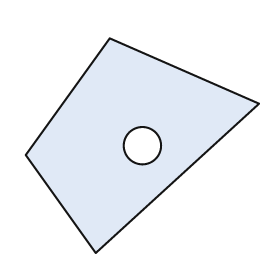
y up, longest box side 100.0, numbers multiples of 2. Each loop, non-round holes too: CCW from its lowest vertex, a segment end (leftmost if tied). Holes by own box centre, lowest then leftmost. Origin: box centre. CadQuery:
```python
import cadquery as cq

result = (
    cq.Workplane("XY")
    .moveTo(-20.0, -46.0)
    .lineTo(50.0, 18.0)
    .lineTo(-14.0, 46.0)
    .lineTo(-50.0, -4.0)
    .close()
    .moveTo(0.0, 0.0)
    .circle(8.0)
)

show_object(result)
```